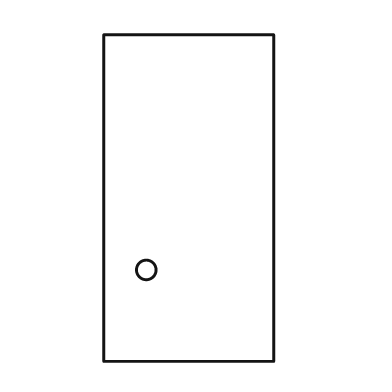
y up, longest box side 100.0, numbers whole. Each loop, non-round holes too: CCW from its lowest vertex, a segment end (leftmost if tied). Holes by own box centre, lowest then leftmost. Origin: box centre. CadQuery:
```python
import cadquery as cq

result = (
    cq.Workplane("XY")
    .moveTo(-26.0, -50.0)
    .lineTo(26.0, -50.0)
    .lineTo(26.0, 50.0)
    .lineTo(-26.0, 50.0)
    .close()
    .moveTo(-13.0, -22.0)
    .circle(3.0)
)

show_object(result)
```